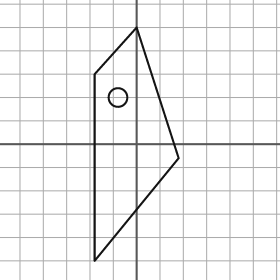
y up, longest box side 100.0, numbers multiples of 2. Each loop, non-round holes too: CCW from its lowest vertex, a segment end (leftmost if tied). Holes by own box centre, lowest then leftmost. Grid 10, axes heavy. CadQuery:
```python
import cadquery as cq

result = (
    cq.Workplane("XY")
    .moveTo(-18.0, -50.0)
    .lineTo(18.0, -6.0)
    .lineTo(0.0, 50.0)
    .lineTo(-18.0, 30.0)
    .close()
    .moveTo(-8.0, 20.0)
    .circle(4.0)
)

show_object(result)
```